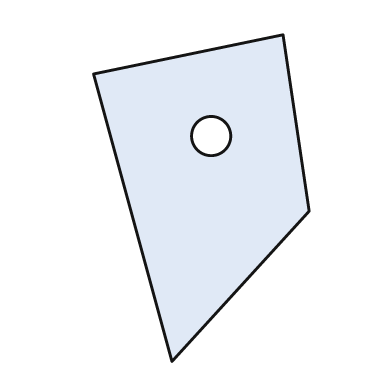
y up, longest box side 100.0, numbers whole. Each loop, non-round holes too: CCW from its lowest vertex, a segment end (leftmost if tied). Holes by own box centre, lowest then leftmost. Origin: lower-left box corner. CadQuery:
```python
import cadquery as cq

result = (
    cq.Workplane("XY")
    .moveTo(24.0, 0.0)
    .lineTo(66.0, 46.0)
    .lineTo(58.0, 100.0)
    .lineTo(0.0, 88.0)
    .close()
    .moveTo(36.0, 69.0)
    .circle(6.0)
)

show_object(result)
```